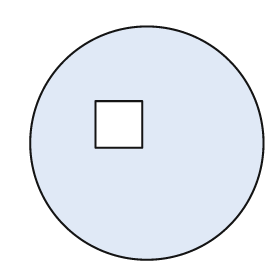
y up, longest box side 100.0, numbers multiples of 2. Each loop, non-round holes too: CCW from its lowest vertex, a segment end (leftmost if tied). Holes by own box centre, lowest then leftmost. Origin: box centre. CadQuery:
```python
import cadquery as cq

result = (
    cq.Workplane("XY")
    .moveTo(0.0, 0.0)
    .circle(50.0)
    .moveTo(-22.0, -2.0)
    .lineTo(-2.0, -2.0)
    .lineTo(-2.0, 18.0)
    .lineTo(-22.0, 18.0)
    .close()
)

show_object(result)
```